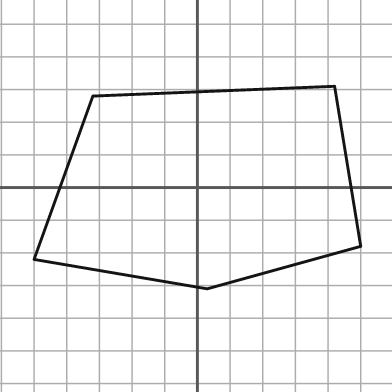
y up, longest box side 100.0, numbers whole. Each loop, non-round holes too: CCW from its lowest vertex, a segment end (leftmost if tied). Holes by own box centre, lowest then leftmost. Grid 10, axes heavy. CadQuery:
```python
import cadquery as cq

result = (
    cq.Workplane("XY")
    .moveTo(3.0, -31.0)
    .lineTo(50.0, -18.0)
    .lineTo(42.0, 31.0)
    .lineTo(-32.0, 28.0)
    .lineTo(-50.0, -22.0)
    .close()
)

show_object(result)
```